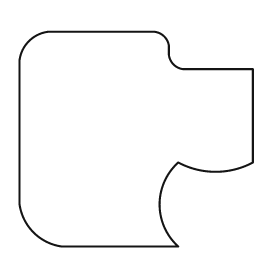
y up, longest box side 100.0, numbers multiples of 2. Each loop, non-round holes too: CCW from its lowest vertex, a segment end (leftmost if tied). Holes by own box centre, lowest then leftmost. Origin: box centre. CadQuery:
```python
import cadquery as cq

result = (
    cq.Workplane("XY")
    .moveTo(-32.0, -46.0)
    .lineTo(18.0, -46.0)
    .threePointArc((10.0, -28.0), (18.0, -10.0))
    .threePointArc((34.0, -14.0), (50.0, -10.0))
    .lineTo(50.0, 30.0)
    .lineTo(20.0, 30.0)
    .threePointArc((16.0, 32.0), (14.0, 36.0))
    .lineTo(14.0, 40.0)
    .threePointArc((12.0, 44.0), (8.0, 46.0))
    .lineTo(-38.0, 46.0)
    .threePointArc((-46.0, 42.0), (-50.0, 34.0))
    .lineTo(-50.0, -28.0)
    .threePointArc((-44.0, -40.0), (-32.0, -46.0))
    .close()
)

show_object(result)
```